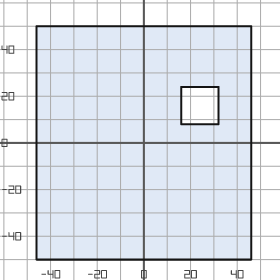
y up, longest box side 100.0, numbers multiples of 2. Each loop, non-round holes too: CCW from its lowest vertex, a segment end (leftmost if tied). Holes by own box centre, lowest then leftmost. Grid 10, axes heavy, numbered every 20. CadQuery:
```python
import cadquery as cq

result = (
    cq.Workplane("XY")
    .moveTo(-46.0, -50.0)
    .lineTo(46.0, -50.0)
    .lineTo(46.0, 50.0)
    .lineTo(-46.0, 50.0)
    .close()
    .moveTo(16.0, 8.0)
    .lineTo(32.0, 8.0)
    .lineTo(32.0, 24.0)
    .lineTo(16.0, 24.0)
    .close()
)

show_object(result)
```